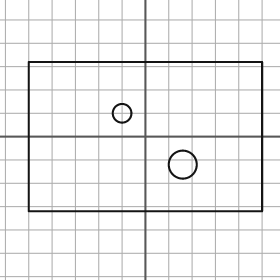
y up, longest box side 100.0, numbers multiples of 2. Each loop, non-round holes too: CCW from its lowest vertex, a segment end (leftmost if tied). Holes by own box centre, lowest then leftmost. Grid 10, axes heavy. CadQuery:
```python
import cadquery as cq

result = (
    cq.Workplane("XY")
    .moveTo(-50.0, -32.0)
    .lineTo(50.0, -32.0)
    .lineTo(50.0, 32.0)
    .lineTo(-50.0, 32.0)
    .close()
    .moveTo(16.0, -12.0)
    .circle(6.0)
    .moveTo(-10.0, 10.0)
    .circle(4.0)
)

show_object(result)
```